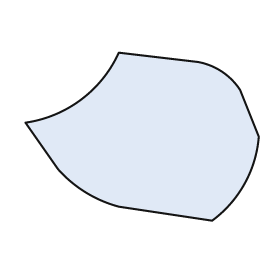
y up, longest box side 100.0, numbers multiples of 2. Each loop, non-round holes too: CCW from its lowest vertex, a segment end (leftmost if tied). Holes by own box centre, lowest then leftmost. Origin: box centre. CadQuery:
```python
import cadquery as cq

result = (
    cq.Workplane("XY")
    .moveTo(30.0, -36.0)
    .threePointArc((44.0, -20.0), (50.0, 0.0))
    .lineTo(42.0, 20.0)
    .threePointArc((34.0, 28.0), (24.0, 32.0))
    .lineTo(-10.0, 36.0)
    .threePointArc((-26.0, 16.0), (-50.0, 6.0))
    .lineTo(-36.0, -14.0)
    .threePointArc((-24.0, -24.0), (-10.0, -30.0))
    .close()
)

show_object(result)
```